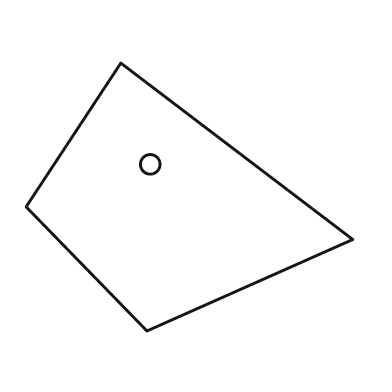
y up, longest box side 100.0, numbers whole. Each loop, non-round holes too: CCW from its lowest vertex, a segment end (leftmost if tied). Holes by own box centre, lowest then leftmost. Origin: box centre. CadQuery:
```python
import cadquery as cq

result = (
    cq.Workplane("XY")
    .moveTo(-13.0, -41.0)
    .lineTo(50.0, -13.0)
    .lineTo(-21.0, 41.0)
    .lineTo(-50.0, -3.0)
    .close()
    .moveTo(-12.0, 10.0)
    .circle(3.0)
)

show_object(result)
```